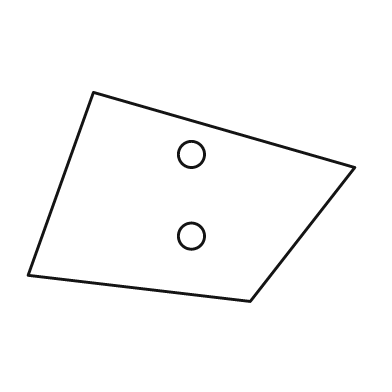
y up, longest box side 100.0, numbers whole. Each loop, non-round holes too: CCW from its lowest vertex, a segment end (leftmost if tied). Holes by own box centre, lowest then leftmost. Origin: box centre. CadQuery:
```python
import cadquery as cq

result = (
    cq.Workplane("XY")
    .moveTo(18.0, -32.0)
    .lineTo(50.0, 9.0)
    .lineTo(-30.0, 32.0)
    .lineTo(-50.0, -24.0)
    .close()
    .moveTo(0.0, -12.0)
    .circle(4.0)
    .moveTo(0.0, 13.0)
    .circle(4.0)
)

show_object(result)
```